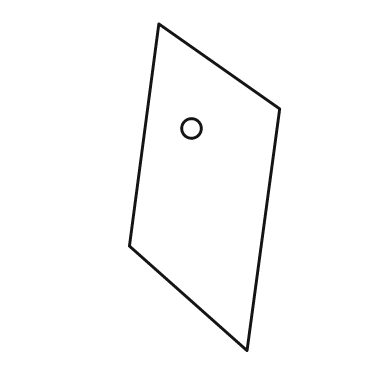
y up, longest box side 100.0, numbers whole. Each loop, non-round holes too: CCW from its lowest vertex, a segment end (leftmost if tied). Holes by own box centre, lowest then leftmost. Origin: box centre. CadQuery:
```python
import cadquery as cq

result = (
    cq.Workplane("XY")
    .moveTo(13.0, -50.0)
    .lineTo(23.0, 24.0)
    .lineTo(-14.0, 50.0)
    .lineTo(-23.0, -18.0)
    .close()
    .moveTo(-4.0, 18.0)
    .circle(3.0)
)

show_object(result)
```